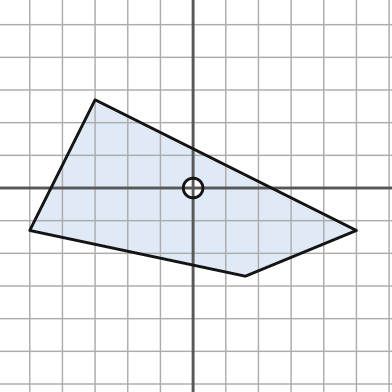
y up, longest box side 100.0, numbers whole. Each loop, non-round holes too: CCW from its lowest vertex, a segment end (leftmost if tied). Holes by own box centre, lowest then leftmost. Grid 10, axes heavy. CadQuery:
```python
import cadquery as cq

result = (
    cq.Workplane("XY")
    .moveTo(16.0, -27.0)
    .lineTo(50.0, -13.0)
    .lineTo(-30.0, 27.0)
    .lineTo(-50.0, -13.0)
    .close()
    .moveTo(0.0, 0.0)
    .circle(3.0)
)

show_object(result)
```